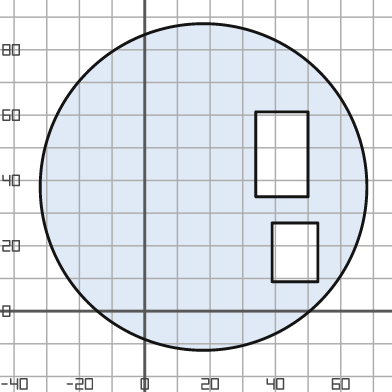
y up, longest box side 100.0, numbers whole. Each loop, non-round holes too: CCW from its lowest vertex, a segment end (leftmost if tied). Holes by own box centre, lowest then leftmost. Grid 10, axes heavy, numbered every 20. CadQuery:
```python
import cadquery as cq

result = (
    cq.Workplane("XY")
    .moveTo(18.0, 38.0)
    .circle(50.0)
    .moveTo(39.0, 9.0)
    .lineTo(53.0, 9.0)
    .lineTo(53.0, 27.0)
    .lineTo(39.0, 27.0)
    .close()
    .moveTo(34.0, 35.0)
    .lineTo(50.0, 35.0)
    .lineTo(50.0, 61.0)
    .lineTo(34.0, 61.0)
    .close()
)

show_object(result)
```